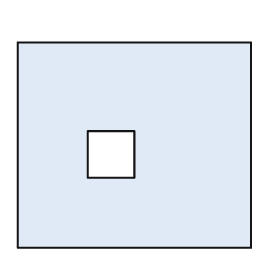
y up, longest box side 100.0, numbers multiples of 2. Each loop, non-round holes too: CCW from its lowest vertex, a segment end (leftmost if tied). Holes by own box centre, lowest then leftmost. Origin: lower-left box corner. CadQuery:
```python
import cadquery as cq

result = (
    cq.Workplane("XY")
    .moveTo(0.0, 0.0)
    .lineTo(100.0, 0.0)
    .lineTo(100.0, 88.0)
    .lineTo(0.0, 88.0)
    .close()
    .moveTo(30.0, 30.0)
    .lineTo(50.0, 30.0)
    .lineTo(50.0, 50.0)
    .lineTo(30.0, 50.0)
    .close()
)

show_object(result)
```